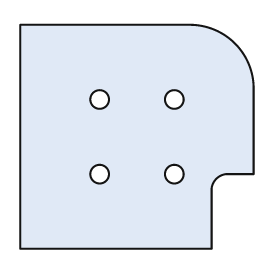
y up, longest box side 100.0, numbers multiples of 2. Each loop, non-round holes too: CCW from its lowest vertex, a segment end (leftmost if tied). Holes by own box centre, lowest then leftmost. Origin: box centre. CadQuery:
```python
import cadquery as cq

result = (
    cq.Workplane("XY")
    .moveTo(-50.0, -48.0)
    .lineTo(32.0, -48.0)
    .lineTo(32.0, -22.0)
    .threePointArc((34.0, -18.0), (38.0, -16.0))
    .lineTo(50.0, -16.0)
    .lineTo(50.0, 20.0)
    .threePointArc((42.0, 40.0), (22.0, 48.0))
    .lineTo(-50.0, 48.0)
    .close()
    .moveTo(-16.0, -16.0)
    .circle(4.0)
    .moveTo(16.0, -16.0)
    .circle(4.0)
    .moveTo(-16.0, 16.0)
    .circle(4.0)
    .moveTo(16.0, 16.0)
    .circle(4.0)
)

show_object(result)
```